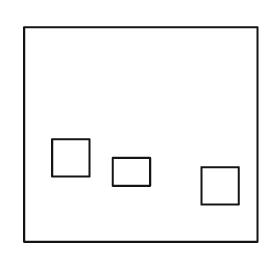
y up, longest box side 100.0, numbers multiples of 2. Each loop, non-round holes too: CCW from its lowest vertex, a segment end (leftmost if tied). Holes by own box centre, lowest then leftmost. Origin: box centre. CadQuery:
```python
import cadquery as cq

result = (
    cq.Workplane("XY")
    .moveTo(-50.0, -46.0)
    .lineTo(50.0, -46.0)
    .lineTo(50.0, 46.0)
    .lineTo(-50.0, 46.0)
    .close()
    .moveTo(26.0, -30.0)
    .lineTo(42.0, -30.0)
    .lineTo(42.0, -14.0)
    .lineTo(26.0, -14.0)
    .close()
    .moveTo(-12.0, -22.0)
    .lineTo(4.0, -22.0)
    .lineTo(4.0, -10.0)
    .lineTo(-12.0, -10.0)
    .close()
    .moveTo(-38.0, -18.0)
    .lineTo(-22.0, -18.0)
    .lineTo(-22.0, -2.0)
    .lineTo(-38.0, -2.0)
    .close()
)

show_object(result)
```